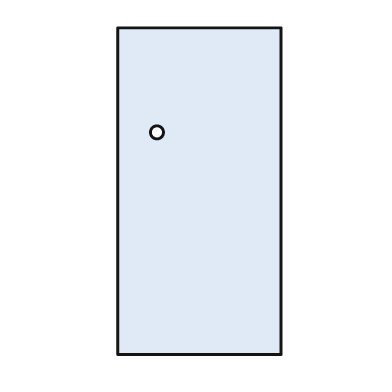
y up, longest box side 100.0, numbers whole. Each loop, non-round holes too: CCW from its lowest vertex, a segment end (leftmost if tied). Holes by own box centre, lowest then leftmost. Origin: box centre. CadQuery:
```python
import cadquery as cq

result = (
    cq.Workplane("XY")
    .moveTo(-25.0, -50.0)
    .lineTo(25.0, -50.0)
    .lineTo(25.0, 50.0)
    .lineTo(-25.0, 50.0)
    .close()
    .moveTo(-13.0, 18.0)
    .circle(2.0)
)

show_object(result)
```